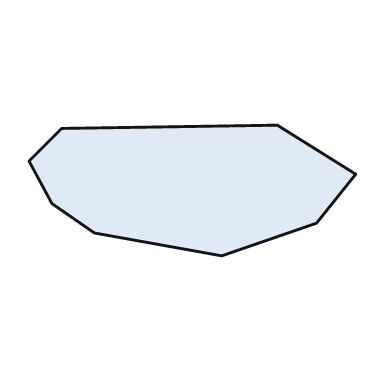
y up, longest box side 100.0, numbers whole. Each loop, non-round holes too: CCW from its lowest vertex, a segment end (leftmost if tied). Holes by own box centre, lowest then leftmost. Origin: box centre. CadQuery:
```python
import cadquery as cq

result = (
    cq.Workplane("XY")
    .moveTo(9.0, -20.0)
    .lineTo(38.0, -10.0)
    .lineTo(50.0, 5.0)
    .lineTo(26.0, 20.0)
    .lineTo(-40.0, 19.0)
    .lineTo(-50.0, 9.0)
    .lineTo(-43.0, -4.0)
    .lineTo(-30.0, -13.0)
    .close()
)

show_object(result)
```